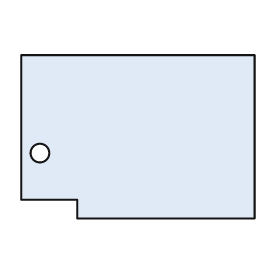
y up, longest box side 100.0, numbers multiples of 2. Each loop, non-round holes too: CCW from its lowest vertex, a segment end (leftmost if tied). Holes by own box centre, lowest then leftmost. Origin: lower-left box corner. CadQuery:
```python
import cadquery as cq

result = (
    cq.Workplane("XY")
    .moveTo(24.0, 0.0)
    .lineTo(100.0, 0.0)
    .lineTo(100.0, 70.0)
    .lineTo(0.0, 70.0)
    .lineTo(0.0, 8.0)
    .lineTo(24.0, 8.0)
    .close()
    .moveTo(8.0, 28.0)
    .circle(4.0)
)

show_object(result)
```